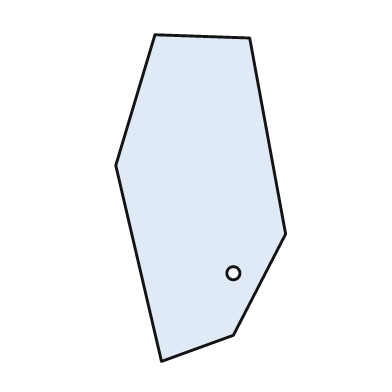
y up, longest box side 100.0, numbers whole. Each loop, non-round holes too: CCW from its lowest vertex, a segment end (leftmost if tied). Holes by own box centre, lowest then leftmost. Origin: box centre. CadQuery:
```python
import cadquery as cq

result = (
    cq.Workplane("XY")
    .moveTo(-12.0, -50.0)
    .lineTo(10.0, -42.0)
    .lineTo(26.0, -11.0)
    .lineTo(15.0, 49.0)
    .lineTo(-14.0, 50.0)
    .lineTo(-26.0, 10.0)
    .close()
    .moveTo(10.0, -23.0)
    .circle(2.0)
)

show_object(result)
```